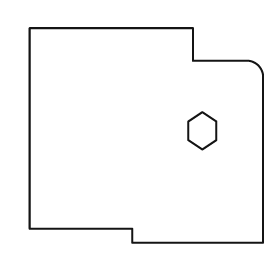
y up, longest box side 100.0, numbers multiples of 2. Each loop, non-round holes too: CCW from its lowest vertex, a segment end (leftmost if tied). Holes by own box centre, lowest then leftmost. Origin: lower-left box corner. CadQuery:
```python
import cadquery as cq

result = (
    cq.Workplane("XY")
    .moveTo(44.0, 0.0)
    .lineTo(100.0, 0.0)
    .lineTo(100.0, 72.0)
    .threePointArc((98.0, 76.0), (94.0, 78.0))
    .lineTo(70.0, 78.0)
    .lineTo(70.0, 92.0)
    .lineTo(0.0, 92.0)
    .lineTo(0.0, 6.0)
    .lineTo(44.0, 6.0)
    .close()
    .moveTo(74.0, 40.0)
    .lineTo(80.0, 44.0)
    .lineTo(80.0, 52.0)
    .lineTo(74.0, 56.0)
    .lineTo(68.0, 52.0)
    .lineTo(68.0, 44.0)
    .close()
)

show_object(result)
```